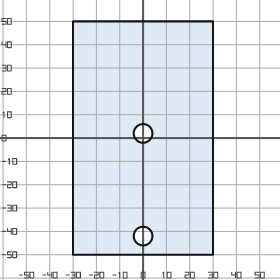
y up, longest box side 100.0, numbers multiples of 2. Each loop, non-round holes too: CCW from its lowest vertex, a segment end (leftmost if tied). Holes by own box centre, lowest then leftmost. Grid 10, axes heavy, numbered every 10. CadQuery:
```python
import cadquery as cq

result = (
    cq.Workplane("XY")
    .moveTo(-30.0, -50.0)
    .lineTo(30.0, -50.0)
    .lineTo(30.0, 50.0)
    .lineTo(-30.0, 50.0)
    .close()
    .moveTo(0.0, -42.0)
    .circle(4.0)
    .moveTo(0.0, 2.0)
    .circle(4.0)
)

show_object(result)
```